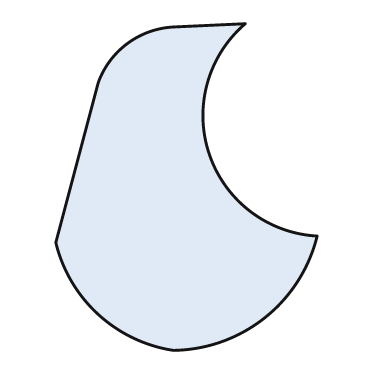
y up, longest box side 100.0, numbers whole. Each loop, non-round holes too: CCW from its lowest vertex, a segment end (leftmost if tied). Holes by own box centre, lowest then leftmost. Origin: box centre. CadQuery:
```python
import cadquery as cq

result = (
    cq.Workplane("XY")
    .moveTo(-4.0, -50.0)
    .threePointArc((24.0, -40.0), (40.0, -15.0))
    .threePointArc((7.0, 10.0), (18.0, 50.0))
    .lineTo(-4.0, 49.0)
    .threePointArc((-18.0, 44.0), (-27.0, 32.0))
    .lineTo(-40.0, -17.0)
    .threePointArc((-27.0, -39.0), (-4.0, -50.0))
    .close()
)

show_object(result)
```